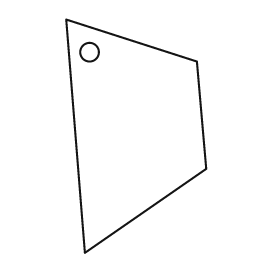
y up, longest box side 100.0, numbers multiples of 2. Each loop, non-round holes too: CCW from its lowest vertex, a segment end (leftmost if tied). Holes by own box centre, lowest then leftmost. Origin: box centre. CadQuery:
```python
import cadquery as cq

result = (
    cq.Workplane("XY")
    .moveTo(-22.0, -50.0)
    .lineTo(30.0, -14.0)
    .lineTo(26.0, 32.0)
    .lineTo(-30.0, 50.0)
    .close()
    .moveTo(-20.0, 36.0)
    .circle(4.0)
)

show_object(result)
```